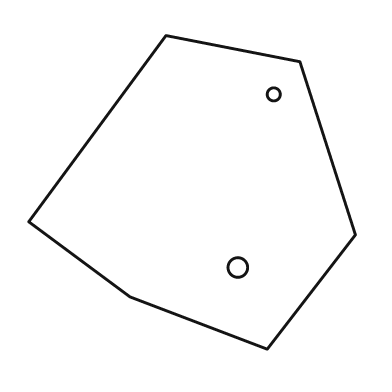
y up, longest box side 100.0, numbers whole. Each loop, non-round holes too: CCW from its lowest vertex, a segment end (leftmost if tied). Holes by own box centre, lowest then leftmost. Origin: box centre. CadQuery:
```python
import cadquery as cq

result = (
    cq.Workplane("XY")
    .moveTo(23.0, -48.0)
    .lineTo(50.0, -13.0)
    .lineTo(33.0, 40.0)
    .lineTo(-8.0, 48.0)
    .lineTo(-50.0, -9.0)
    .lineTo(-19.0, -32.0)
    .close()
    .moveTo(14.0, -23.0)
    .circle(3.0)
    .moveTo(25.0, 30.0)
    .circle(2.0)
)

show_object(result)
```